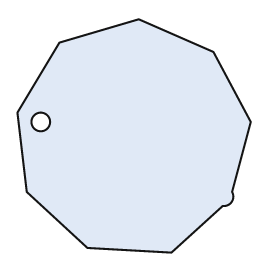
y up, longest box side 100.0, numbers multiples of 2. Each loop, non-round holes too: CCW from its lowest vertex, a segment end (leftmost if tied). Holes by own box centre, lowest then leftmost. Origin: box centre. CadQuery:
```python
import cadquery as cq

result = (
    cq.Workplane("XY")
    .moveTo(16.0, -50.0)
    .lineTo(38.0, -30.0)
    .threePointArc((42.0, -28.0), (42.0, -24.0))
    .lineTo(50.0, 6.0)
    .lineTo(34.0, 36.0)
    .lineTo(2.0, 50.0)
    .lineTo(-32.0, 40.0)
    .lineTo(-50.0, 10.0)
    .lineTo(-46.0, -24.0)
    .lineTo(-20.0, -48.0)
    .close()
    .moveTo(-40.0, 6.0)
    .circle(4.0)
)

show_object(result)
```